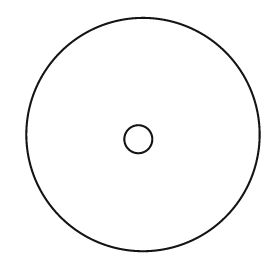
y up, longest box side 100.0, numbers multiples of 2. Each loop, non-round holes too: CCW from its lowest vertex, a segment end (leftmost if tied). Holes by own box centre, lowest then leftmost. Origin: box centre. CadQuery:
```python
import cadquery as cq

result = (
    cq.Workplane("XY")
    .moveTo(0.0, 0.0)
    .circle(50.0)
    .moveTo(-2.0, -2.0)
    .circle(6.0)
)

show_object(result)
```